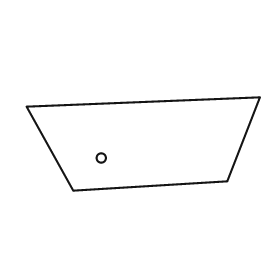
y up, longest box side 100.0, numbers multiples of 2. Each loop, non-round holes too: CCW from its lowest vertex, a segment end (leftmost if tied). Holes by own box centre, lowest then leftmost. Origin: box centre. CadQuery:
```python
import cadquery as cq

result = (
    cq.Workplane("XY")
    .moveTo(-30.0, -20.0)
    .lineTo(36.0, -16.0)
    .lineTo(50.0, 20.0)
    .lineTo(-50.0, 16.0)
    .close()
    .moveTo(-18.0, -6.0)
    .circle(2.0)
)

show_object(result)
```